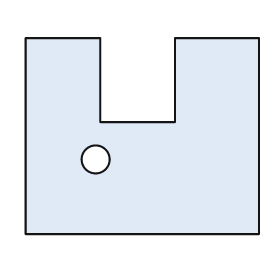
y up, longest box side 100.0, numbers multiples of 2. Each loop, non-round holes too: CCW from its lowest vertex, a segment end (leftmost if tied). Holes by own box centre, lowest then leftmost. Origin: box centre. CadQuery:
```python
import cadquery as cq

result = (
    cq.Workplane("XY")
    .moveTo(-50.0, -42.0)
    .lineTo(50.0, -42.0)
    .lineTo(50.0, 42.0)
    .lineTo(14.0, 42.0)
    .lineTo(14.0, 6.0)
    .lineTo(-18.0, 6.0)
    .lineTo(-18.0, 42.0)
    .lineTo(-50.0, 42.0)
    .close()
    .moveTo(-20.0, -10.0)
    .circle(6.0)
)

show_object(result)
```